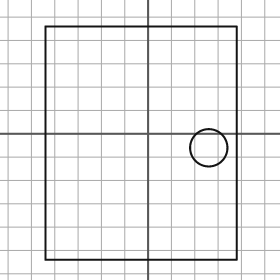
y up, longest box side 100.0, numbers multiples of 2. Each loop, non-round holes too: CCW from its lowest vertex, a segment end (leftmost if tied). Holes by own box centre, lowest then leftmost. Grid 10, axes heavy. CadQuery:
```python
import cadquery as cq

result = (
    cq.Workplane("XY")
    .moveTo(-44.0, -54.0)
    .lineTo(38.0, -54.0)
    .lineTo(38.0, 46.0)
    .lineTo(-44.0, 46.0)
    .close()
    .moveTo(26.0, -6.0)
    .circle(8.0)
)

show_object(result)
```